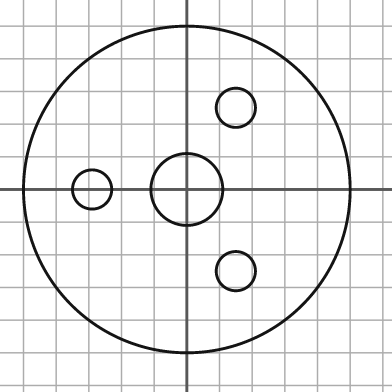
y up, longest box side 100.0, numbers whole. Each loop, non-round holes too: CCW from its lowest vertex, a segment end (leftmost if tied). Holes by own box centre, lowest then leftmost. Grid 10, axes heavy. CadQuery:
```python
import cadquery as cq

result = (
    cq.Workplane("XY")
    .moveTo(0.0, 0.0)
    .circle(50.0)
    .moveTo(15.0, -25.0)
    .circle(6.0)
    .moveTo(-29.0, 0.0)
    .circle(6.0)
    .moveTo(0.0, 0.0)
    .circle(11.0)
    .moveTo(15.0, 25.0)
    .circle(6.0)
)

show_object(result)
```